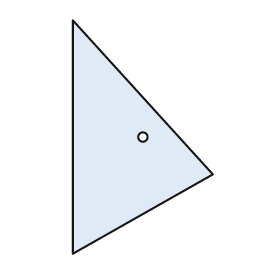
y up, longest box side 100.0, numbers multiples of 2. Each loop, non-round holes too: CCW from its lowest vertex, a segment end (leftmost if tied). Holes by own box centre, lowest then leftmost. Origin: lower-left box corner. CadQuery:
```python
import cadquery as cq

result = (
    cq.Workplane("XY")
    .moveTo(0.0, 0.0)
    .lineTo(60.0, 34.0)
    .lineTo(0.0, 100.0)
    .close()
    .moveTo(30.0, 50.0)
    .circle(2.0)
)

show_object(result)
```